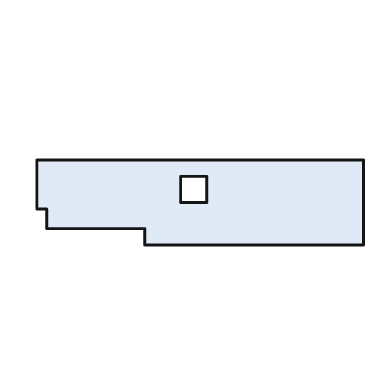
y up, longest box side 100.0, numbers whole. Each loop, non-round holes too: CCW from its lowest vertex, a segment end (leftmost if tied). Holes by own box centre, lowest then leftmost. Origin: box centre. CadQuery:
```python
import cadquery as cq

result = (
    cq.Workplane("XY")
    .moveTo(-17.0, -13.0)
    .lineTo(50.0, -13.0)
    .lineTo(50.0, 13.0)
    .lineTo(-50.0, 13.0)
    .lineTo(-50.0, -2.0)
    .lineTo(-47.0, -2.0)
    .lineTo(-47.0, -8.0)
    .lineTo(-17.0, -8.0)
    .close()
    .moveTo(-6.0, 0.0)
    .lineTo(2.0, 0.0)
    .lineTo(2.0, 8.0)
    .lineTo(-6.0, 8.0)
    .close()
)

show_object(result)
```